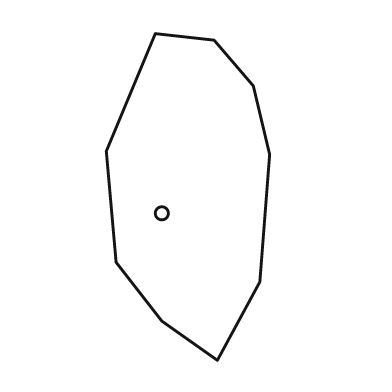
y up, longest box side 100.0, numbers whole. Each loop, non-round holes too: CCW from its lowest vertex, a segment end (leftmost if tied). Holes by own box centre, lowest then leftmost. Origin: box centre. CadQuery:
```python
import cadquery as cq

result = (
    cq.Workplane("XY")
    .moveTo(9.0, -50.0)
    .lineTo(22.0, -26.0)
    .lineTo(25.0, 13.0)
    .lineTo(20.0, 34.0)
    .lineTo(8.0, 48.0)
    .lineTo(-10.0, 50.0)
    .lineTo(-25.0, 14.0)
    .lineTo(-22.0, -20.0)
    .lineTo(-8.0, -38.0)
    .close()
    .moveTo(-8.0, -5.0)
    .circle(2.0)
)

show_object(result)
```